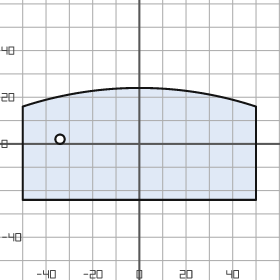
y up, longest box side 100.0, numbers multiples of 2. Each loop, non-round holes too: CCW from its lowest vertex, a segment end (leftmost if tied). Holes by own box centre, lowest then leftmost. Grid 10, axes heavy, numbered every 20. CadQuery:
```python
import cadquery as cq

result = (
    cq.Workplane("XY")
    .moveTo(-50.0, -24.0)
    .lineTo(50.0, -24.0)
    .lineTo(50.0, 16.0)
    .threePointArc((0.0, 24.0), (-50.0, 16.0))
    .close()
    .moveTo(-34.0, 2.0)
    .circle(2.0)
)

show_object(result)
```